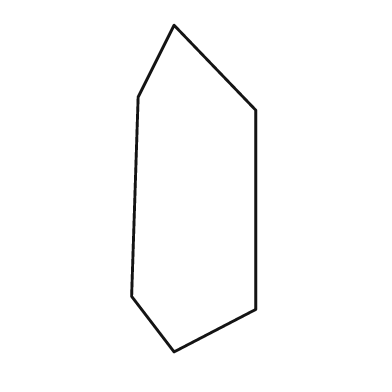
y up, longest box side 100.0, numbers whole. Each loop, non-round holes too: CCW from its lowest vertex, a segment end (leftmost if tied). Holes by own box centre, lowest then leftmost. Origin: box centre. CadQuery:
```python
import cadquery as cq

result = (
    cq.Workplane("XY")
    .moveTo(-6.0, -50.0)
    .lineTo(19.0, -37.0)
    .lineTo(19.0, 24.0)
    .lineTo(-6.0, 50.0)
    .lineTo(-17.0, 28.0)
    .lineTo(-19.0, -33.0)
    .close()
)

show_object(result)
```